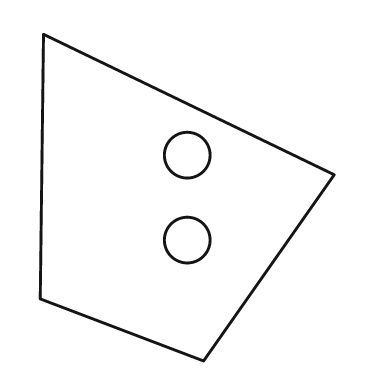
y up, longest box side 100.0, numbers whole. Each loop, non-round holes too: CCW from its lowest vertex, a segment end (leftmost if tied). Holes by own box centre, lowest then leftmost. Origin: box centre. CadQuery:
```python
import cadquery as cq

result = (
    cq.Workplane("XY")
    .moveTo(5.0, -50.0)
    .lineTo(45.0, 7.0)
    .lineTo(-44.0, 50.0)
    .lineTo(-45.0, -31.0)
    .close()
    .moveTo(0.0, -13.0)
    .circle(7.0)
    .moveTo(0.0, 13.0)
    .circle(7.0)
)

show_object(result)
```